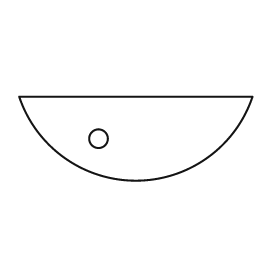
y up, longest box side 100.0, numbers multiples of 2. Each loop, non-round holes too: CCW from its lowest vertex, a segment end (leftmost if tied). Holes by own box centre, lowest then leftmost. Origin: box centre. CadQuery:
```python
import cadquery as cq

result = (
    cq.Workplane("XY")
    .moveTo(-50.0, 18.0)
    .threePointArc((0.0, -18.0), (50.0, 18.0))
    .close()
    .moveTo(-16.0, 0.0)
    .circle(4.0)
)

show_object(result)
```